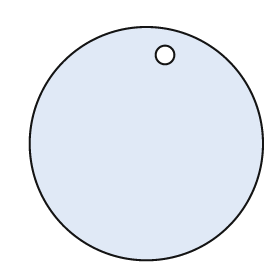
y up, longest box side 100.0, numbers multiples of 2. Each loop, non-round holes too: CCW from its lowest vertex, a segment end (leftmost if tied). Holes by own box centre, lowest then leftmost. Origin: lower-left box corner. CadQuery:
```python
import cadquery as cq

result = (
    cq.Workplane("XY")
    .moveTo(50.0, 50.0)
    .circle(50.0)
    .moveTo(58.0, 88.0)
    .circle(4.0)
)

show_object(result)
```